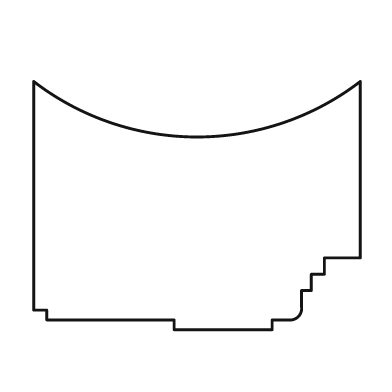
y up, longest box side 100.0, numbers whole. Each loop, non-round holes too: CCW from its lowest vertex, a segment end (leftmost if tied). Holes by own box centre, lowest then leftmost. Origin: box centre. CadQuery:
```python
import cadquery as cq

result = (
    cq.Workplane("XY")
    .moveTo(-7.0, -38.0)
    .lineTo(23.0, -38.0)
    .lineTo(23.0, -35.0)
    .lineTo(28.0, -35.0)
    .threePointArc((31.0, -34.0), (32.0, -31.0))
    .lineTo(32.0, -26.0)
    .lineTo(35.0, -26.0)
    .lineTo(35.0, -21.0)
    .lineTo(39.0, -21.0)
    .lineTo(39.0, -16.0)
    .lineTo(50.0, -16.0)
    .lineTo(50.0, 38.0)
    .threePointArc((0.0, 21.0), (-50.0, 38.0))
    .lineTo(-50.0, -32.0)
    .lineTo(-46.0, -32.0)
    .lineTo(-46.0, -35.0)
    .lineTo(-7.0, -35.0)
    .close()
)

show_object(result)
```